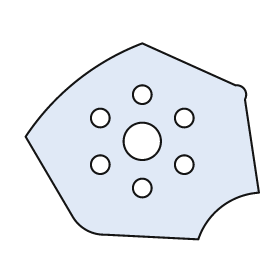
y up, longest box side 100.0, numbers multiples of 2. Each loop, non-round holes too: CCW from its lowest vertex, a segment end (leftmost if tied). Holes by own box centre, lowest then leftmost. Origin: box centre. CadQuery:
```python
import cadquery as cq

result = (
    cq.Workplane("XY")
    .moveTo(24.0, -42.0)
    .threePointArc((34.0, -28.0), (50.0, -22.0))
    .lineTo(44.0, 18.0)
    .threePointArc((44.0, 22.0), (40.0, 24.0))
    .lineTo(0.0, 42.0)
    .threePointArc((-28.0, 26.0), (-50.0, 2.0))
    .lineTo(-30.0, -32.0)
    .threePointArc((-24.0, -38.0), (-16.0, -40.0))
    .close()
    .moveTo(0.0, -20.0)
    .circle(4.0)
    .moveTo(-18.0, -10.0)
    .circle(4.0)
    .moveTo(18.0, -10.0)
    .circle(4.0)
    .moveTo(0.0, 0.0)
    .circle(8.0)
    .moveTo(-18.0, 10.0)
    .circle(4.0)
    .moveTo(18.0, 10.0)
    .circle(4.0)
    .moveTo(0.0, 20.0)
    .circle(4.0)
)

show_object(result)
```